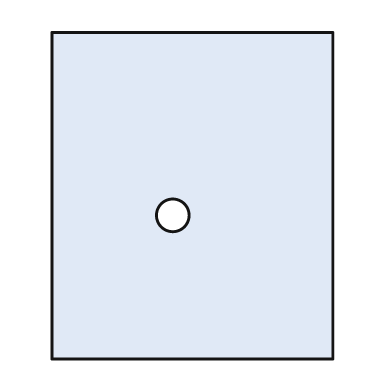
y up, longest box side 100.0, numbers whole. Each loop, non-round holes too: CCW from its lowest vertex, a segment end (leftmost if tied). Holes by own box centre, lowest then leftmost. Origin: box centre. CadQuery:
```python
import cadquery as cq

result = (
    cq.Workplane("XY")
    .moveTo(-43.0, -50.0)
    .lineTo(43.0, -50.0)
    .lineTo(43.0, 50.0)
    .lineTo(-43.0, 50.0)
    .close()
    .moveTo(-6.0, -6.0)
    .circle(5.0)
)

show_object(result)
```